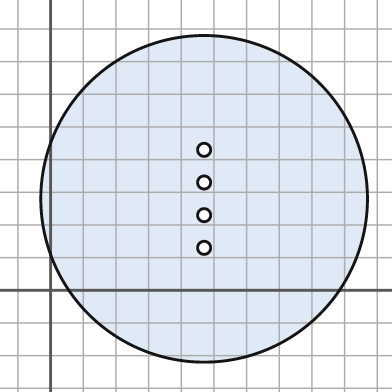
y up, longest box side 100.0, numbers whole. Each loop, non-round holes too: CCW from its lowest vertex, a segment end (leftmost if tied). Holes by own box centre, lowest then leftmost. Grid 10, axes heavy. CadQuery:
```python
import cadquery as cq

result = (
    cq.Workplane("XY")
    .moveTo(47.0, 28.0)
    .circle(50.0)
    .moveTo(47.0, 13.0)
    .circle(2.0)
    .moveTo(47.0, 23.0)
    .circle(2.0)
    .moveTo(47.0, 33.0)
    .circle(2.0)
    .moveTo(47.0, 43.0)
    .circle(2.0)
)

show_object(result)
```